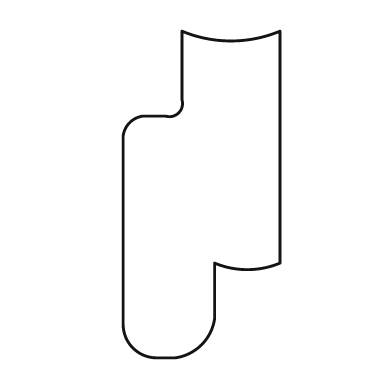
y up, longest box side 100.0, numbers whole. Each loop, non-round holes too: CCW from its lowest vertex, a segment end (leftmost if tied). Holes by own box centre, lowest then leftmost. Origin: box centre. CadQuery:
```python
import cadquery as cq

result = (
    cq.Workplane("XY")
    .moveTo(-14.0, -50.0)
    .lineTo(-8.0, -50.0)
    .threePointArc((0.0, -46.0), (4.0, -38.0))
    .lineTo(4.0, -21.0)
    .threePointArc((14.0, -23.0), (24.0, -21.0))
    .lineTo(24.0, 50.0)
    .threePointArc((9.0, 47.0), (-6.0, 50.0))
    .lineTo(-6.0, 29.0)
    .threePointArc((-7.0, 25.0), (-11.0, 24.0))
    .lineTo(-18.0, 24.0)
    .threePointArc((-22.0, 22.0), (-24.0, 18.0))
    .lineTo(-24.0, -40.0)
    .threePointArc((-21.0, -47.0), (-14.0, -50.0))
    .close()
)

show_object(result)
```